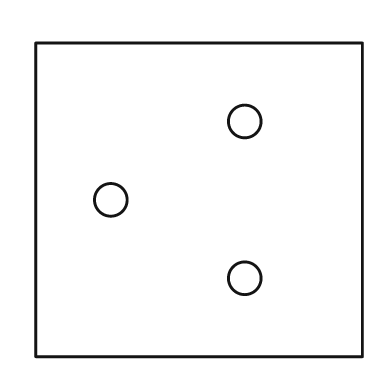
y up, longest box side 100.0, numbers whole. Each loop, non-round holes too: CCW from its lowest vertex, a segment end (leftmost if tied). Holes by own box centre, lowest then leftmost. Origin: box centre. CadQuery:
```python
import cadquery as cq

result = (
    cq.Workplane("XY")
    .moveTo(-50.0, -48.0)
    .lineTo(50.0, -48.0)
    .lineTo(50.0, 48.0)
    .lineTo(-50.0, 48.0)
    .close()
    .moveTo(14.0, -24.0)
    .circle(5.0)
    .moveTo(-27.0, 0.0)
    .circle(5.0)
    .moveTo(14.0, 24.0)
    .circle(5.0)
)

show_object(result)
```